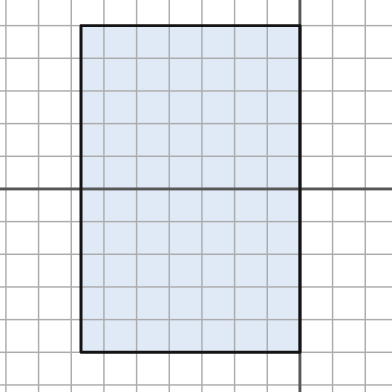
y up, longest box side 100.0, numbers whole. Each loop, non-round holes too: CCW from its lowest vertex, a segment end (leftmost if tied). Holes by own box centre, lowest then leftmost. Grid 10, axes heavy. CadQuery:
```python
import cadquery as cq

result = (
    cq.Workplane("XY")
    .moveTo(-67.0, -50.0)
    .lineTo(0.0, -50.0)
    .lineTo(0.0, 50.0)
    .lineTo(-67.0, 50.0)
    .close()
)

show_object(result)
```